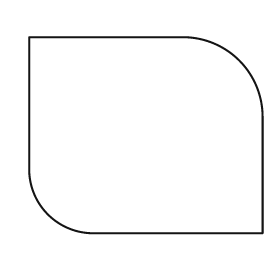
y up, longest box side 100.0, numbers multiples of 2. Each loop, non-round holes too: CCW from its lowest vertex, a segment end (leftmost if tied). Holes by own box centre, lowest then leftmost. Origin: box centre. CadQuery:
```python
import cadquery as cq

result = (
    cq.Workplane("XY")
    .moveTo(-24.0, -42.0)
    .lineTo(50.0, -42.0)
    .lineTo(50.0, 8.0)
    .threePointArc((40.0, 32.0), (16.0, 42.0))
    .lineTo(-50.0, 42.0)
    .lineTo(-50.0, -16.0)
    .threePointArc((-42.0, -34.0), (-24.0, -42.0))
    .close()
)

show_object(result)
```